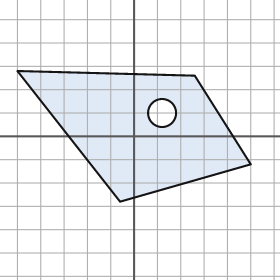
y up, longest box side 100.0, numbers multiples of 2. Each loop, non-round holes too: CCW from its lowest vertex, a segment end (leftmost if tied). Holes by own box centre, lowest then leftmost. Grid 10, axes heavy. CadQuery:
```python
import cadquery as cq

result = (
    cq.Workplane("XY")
    .moveTo(-6.0, -28.0)
    .lineTo(50.0, -12.0)
    .lineTo(26.0, 26.0)
    .lineTo(-50.0, 28.0)
    .close()
    .moveTo(12.0, 10.0)
    .circle(6.0)
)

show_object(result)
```